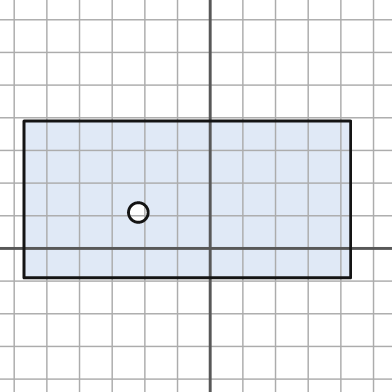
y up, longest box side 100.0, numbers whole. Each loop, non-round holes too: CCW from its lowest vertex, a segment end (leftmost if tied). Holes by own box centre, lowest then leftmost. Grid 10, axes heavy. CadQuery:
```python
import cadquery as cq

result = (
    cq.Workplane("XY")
    .moveTo(-57.0, -9.0)
    .lineTo(43.0, -9.0)
    .lineTo(43.0, 39.0)
    .lineTo(-57.0, 39.0)
    .close()
    .moveTo(-22.0, 11.0)
    .circle(3.0)
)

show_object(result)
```